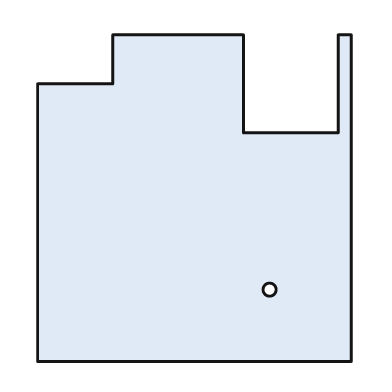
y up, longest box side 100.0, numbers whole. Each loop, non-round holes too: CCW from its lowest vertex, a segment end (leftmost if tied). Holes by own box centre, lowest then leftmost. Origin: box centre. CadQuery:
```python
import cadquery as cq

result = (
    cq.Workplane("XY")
    .moveTo(-48.0, -50.0)
    .lineTo(48.0, -50.0)
    .lineTo(48.0, 50.0)
    .lineTo(44.0, 50.0)
    .lineTo(44.0, 20.0)
    .lineTo(15.0, 20.0)
    .lineTo(15.0, 50.0)
    .lineTo(-25.0, 50.0)
    .lineTo(-25.0, 35.0)
    .lineTo(-48.0, 35.0)
    .close()
    .moveTo(23.0, -28.0)
    .circle(2.0)
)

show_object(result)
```